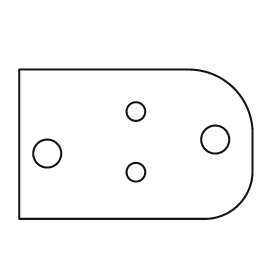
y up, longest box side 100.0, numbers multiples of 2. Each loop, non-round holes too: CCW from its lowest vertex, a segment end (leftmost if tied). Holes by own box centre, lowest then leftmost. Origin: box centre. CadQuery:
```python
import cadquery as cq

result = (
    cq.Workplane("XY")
    .moveTo(-50.0, -32.0)
    .lineTo(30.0, -32.0)
    .threePointArc((44.0, -26.0), (50.0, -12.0))
    .lineTo(50.0, 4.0)
    .threePointArc((42.0, 24.0), (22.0, 32.0))
    .lineTo(-50.0, 32.0)
    .close()
    .moveTo(0.0, -12.0)
    .circle(4.0)
    .moveTo(-38.0, -4.0)
    .circle(6.0)
    .moveTo(34.0, 2.0)
    .circle(6.0)
    .moveTo(0.0, 14.0)
    .circle(4.0)
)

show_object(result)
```